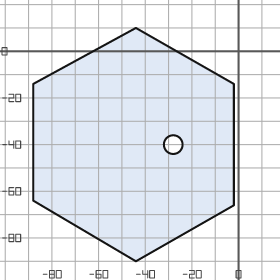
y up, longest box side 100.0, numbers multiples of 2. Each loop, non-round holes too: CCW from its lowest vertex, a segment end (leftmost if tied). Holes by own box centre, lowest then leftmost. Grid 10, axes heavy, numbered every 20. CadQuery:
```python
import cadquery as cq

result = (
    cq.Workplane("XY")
    .moveTo(-44.0, -90.0)
    .lineTo(-2.0, -66.0)
    .lineTo(-2.0, -14.0)
    .lineTo(-44.0, 10.0)
    .lineTo(-88.0, -14.0)
    .lineTo(-88.0, -64.0)
    .close()
    .moveTo(-28.0, -40.0)
    .circle(4.0)
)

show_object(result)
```